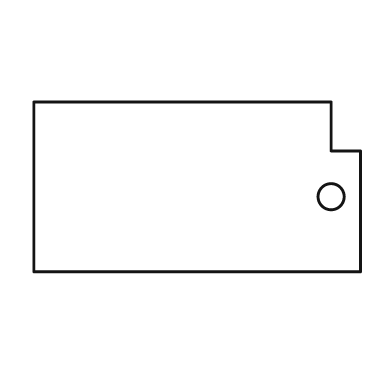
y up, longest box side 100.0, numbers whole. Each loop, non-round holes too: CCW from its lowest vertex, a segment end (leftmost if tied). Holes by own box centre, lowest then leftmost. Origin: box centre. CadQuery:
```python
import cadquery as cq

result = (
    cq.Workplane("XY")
    .moveTo(-50.0, -26.0)
    .lineTo(50.0, -26.0)
    .lineTo(50.0, 11.0)
    .lineTo(41.0, 11.0)
    .lineTo(41.0, 26.0)
    .lineTo(-50.0, 26.0)
    .close()
    .moveTo(41.0, -3.0)
    .circle(4.0)
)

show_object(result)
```